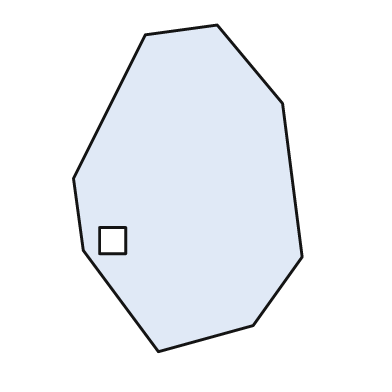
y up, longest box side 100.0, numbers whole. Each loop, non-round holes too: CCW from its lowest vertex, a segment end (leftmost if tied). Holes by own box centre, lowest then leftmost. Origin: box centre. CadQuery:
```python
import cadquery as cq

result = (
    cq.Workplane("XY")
    .moveTo(-9.0, -50.0)
    .lineTo(20.0, -42.0)
    .lineTo(35.0, -21.0)
    .lineTo(29.0, 26.0)
    .lineTo(9.0, 50.0)
    .lineTo(-13.0, 47.0)
    .lineTo(-35.0, 3.0)
    .lineTo(-32.0, -19.0)
    .close()
    .moveTo(-27.0, -20.0)
    .lineTo(-19.0, -20.0)
    .lineTo(-19.0, -12.0)
    .lineTo(-27.0, -12.0)
    .close()
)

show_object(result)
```